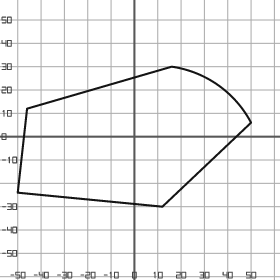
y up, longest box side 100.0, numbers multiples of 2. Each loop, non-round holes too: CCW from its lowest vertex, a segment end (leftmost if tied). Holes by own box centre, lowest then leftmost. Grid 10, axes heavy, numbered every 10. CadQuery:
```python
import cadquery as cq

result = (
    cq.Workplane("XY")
    .moveTo(12.0, -30.0)
    .lineTo(50.0, 6.0)
    .threePointArc((36.0, 22.0), (16.0, 30.0))
    .lineTo(-46.0, 12.0)
    .lineTo(-50.0, -24.0)
    .close()
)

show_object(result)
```